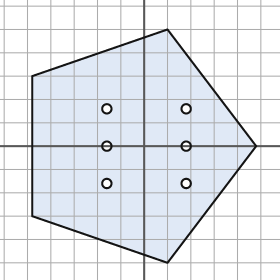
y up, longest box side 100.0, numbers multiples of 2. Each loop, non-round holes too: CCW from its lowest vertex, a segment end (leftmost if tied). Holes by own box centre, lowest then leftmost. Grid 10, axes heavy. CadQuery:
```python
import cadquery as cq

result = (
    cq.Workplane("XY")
    .moveTo(10.0, -50.0)
    .lineTo(48.0, 0.0)
    .lineTo(10.0, 50.0)
    .lineTo(-48.0, 30.0)
    .lineTo(-48.0, -30.0)
    .close()
    .moveTo(-16.0, -16.0)
    .circle(2.0)
    .moveTo(18.0, -16.0)
    .circle(2.0)
    .moveTo(-16.0, 0.0)
    .circle(2.0)
    .moveTo(18.0, 0.0)
    .circle(2.0)
    .moveTo(-16.0, 16.0)
    .circle(2.0)
    .moveTo(18.0, 16.0)
    .circle(2.0)
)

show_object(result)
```